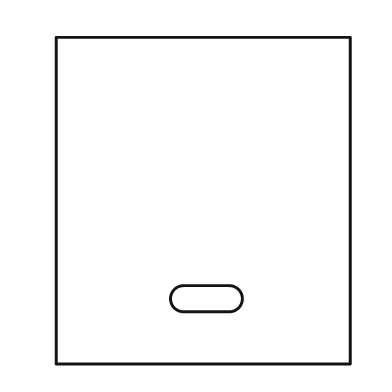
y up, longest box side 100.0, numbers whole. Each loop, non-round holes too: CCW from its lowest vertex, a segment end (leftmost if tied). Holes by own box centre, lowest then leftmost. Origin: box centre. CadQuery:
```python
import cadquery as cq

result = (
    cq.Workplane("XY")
    .moveTo(-45.0, -50.0)
    .lineTo(45.0, -50.0)
    .lineTo(45.0, 50.0)
    .lineTo(-45.0, 50.0)
    .close()
    .moveTo(-6.0, -34.0)
    .lineTo(8.0, -34.0)
    .threePointArc((12.0, -30.0), (8.0, -26.0))
    .lineTo(-6.0, -26.0)
    .threePointArc((-10.0, -30.0), (-6.0, -34.0))
    .close()
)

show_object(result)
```